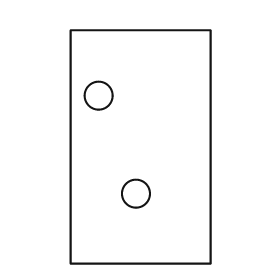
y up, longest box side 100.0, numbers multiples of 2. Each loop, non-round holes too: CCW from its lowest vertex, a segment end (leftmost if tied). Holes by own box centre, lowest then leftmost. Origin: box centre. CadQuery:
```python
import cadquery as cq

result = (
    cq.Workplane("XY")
    .moveTo(-30.0, -50.0)
    .lineTo(30.0, -50.0)
    .lineTo(30.0, 50.0)
    .lineTo(-30.0, 50.0)
    .close()
    .moveTo(-2.0, -20.0)
    .circle(6.0)
    .moveTo(-18.0, 22.0)
    .circle(6.0)
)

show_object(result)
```